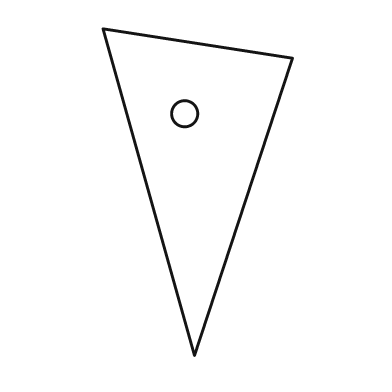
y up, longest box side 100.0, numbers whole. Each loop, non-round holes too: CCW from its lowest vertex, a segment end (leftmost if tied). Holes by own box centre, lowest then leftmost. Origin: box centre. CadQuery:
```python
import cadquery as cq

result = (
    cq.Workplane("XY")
    .moveTo(-1.0, -50.0)
    .lineTo(29.0, 41.0)
    .lineTo(-29.0, 50.0)
    .close()
    .moveTo(-4.0, 24.0)
    .circle(4.0)
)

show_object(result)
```